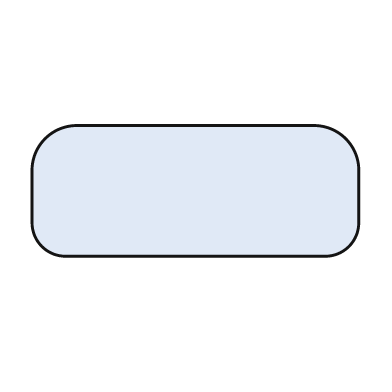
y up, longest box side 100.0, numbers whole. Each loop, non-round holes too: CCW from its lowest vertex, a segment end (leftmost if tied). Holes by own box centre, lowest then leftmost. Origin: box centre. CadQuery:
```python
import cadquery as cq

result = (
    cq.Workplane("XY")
    .moveTo(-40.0, -20.0)
    .lineTo(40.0, -20.0)
    .threePointArc((47.0, -17.0), (50.0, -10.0))
    .lineTo(50.0, 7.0)
    .threePointArc((46.0, 16.0), (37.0, 20.0))
    .lineTo(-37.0, 20.0)
    .threePointArc((-46.0, 16.0), (-50.0, 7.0))
    .lineTo(-50.0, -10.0)
    .threePointArc((-47.0, -17.0), (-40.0, -20.0))
    .close()
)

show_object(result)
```